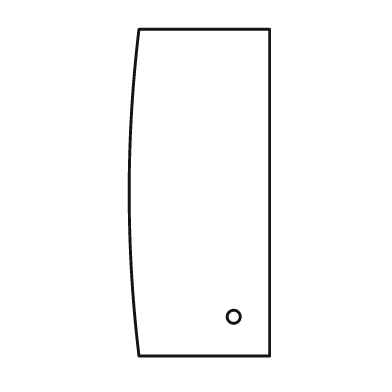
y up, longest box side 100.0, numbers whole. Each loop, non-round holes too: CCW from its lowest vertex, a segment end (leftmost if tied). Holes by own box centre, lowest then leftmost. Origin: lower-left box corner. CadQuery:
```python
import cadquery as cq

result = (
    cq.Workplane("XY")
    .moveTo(3.0, 0.0)
    .lineTo(43.0, 0.0)
    .lineTo(43.0, 100.0)
    .lineTo(3.0, 100.0)
    .threePointArc((0.0, 50.0), (3.0, 0.0))
    .close()
    .moveTo(32.0, 12.0)
    .circle(2.0)
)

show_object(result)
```